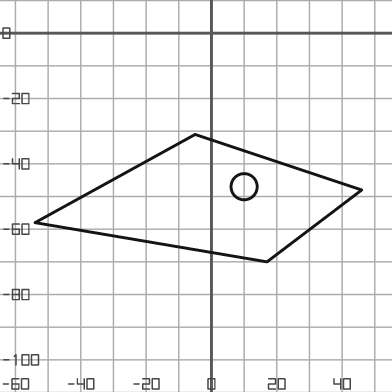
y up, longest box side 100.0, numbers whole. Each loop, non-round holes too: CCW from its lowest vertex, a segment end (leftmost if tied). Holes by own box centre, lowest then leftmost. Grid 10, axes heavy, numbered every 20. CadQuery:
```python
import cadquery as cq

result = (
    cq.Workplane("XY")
    .moveTo(17.0, -70.0)
    .lineTo(46.0, -48.0)
    .lineTo(-5.0, -31.0)
    .lineTo(-54.0, -58.0)
    .close()
    .moveTo(10.0, -47.0)
    .circle(4.0)
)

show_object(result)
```